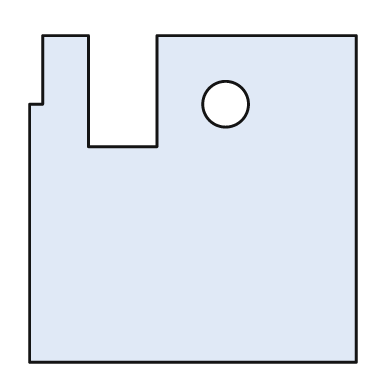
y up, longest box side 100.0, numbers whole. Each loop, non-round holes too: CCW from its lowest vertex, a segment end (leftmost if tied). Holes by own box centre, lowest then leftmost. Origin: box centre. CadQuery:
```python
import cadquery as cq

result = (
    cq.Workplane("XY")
    .moveTo(-50.0, -50.0)
    .lineTo(50.0, -50.0)
    .lineTo(50.0, 50.0)
    .lineTo(-11.0, 50.0)
    .lineTo(-11.0, 16.0)
    .lineTo(-32.0, 16.0)
    .lineTo(-32.0, 50.0)
    .lineTo(-46.0, 50.0)
    .lineTo(-46.0, 29.0)
    .lineTo(-50.0, 29.0)
    .close()
    .moveTo(10.0, 29.0)
    .circle(7.0)
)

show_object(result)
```